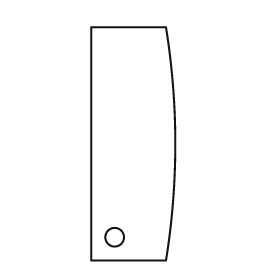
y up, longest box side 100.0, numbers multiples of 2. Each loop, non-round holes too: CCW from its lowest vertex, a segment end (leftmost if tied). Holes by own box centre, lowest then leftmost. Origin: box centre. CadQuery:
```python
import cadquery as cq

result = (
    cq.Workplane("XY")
    .moveTo(-18.0, -50.0)
    .lineTo(14.0, -50.0)
    .threePointArc((18.0, 0.0), (14.0, 50.0))
    .lineTo(-18.0, 50.0)
    .close()
    .moveTo(-8.0, -40.0)
    .circle(4.0)
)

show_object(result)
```